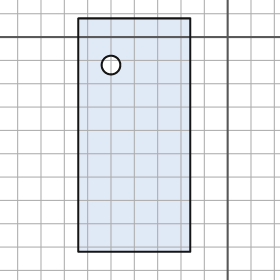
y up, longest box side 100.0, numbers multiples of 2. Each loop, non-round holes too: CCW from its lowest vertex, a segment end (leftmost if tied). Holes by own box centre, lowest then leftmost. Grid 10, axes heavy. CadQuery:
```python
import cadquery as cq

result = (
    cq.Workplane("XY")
    .moveTo(-64.0, -92.0)
    .lineTo(-16.0, -92.0)
    .lineTo(-16.0, 8.0)
    .lineTo(-64.0, 8.0)
    .close()
    .moveTo(-50.0, -12.0)
    .circle(4.0)
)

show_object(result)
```